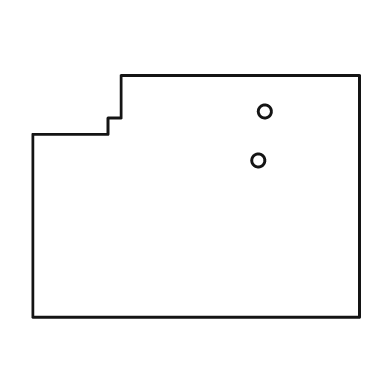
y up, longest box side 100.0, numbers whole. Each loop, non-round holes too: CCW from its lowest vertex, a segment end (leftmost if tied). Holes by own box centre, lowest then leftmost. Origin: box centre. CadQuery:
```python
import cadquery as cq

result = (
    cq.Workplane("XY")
    .moveTo(-50.0, -37.0)
    .lineTo(50.0, -37.0)
    .lineTo(50.0, 37.0)
    .lineTo(-23.0, 37.0)
    .lineTo(-23.0, 24.0)
    .lineTo(-27.0, 24.0)
    .lineTo(-27.0, 19.0)
    .lineTo(-50.0, 19.0)
    .close()
    .moveTo(19.0, 11.0)
    .circle(2.0)
    .moveTo(21.0, 26.0)
    .circle(2.0)
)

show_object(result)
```